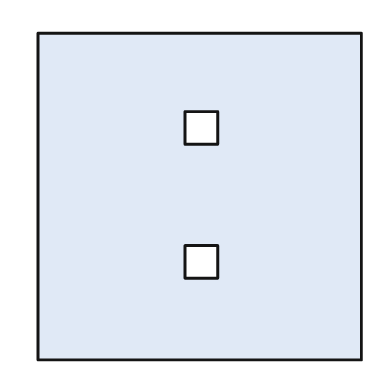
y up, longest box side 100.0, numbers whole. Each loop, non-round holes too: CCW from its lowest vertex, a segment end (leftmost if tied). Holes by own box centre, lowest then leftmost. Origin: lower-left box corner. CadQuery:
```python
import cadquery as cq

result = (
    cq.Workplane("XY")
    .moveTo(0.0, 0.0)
    .lineTo(99.0, 0.0)
    .lineTo(99.0, 100.0)
    .lineTo(0.0, 100.0)
    .close()
    .moveTo(45.0, 25.0)
    .lineTo(55.0, 25.0)
    .lineTo(55.0, 35.0)
    .lineTo(45.0, 35.0)
    .close()
    .moveTo(45.0, 66.0)
    .lineTo(55.0, 66.0)
    .lineTo(55.0, 76.0)
    .lineTo(45.0, 76.0)
    .close()
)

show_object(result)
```